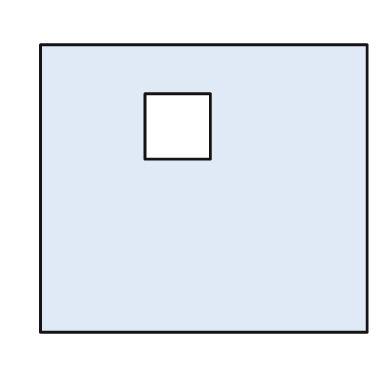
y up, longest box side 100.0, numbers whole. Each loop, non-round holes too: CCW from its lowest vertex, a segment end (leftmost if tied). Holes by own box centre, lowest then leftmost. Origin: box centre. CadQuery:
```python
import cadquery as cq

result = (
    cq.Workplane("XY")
    .moveTo(-50.0, -44.0)
    .lineTo(50.0, -44.0)
    .lineTo(50.0, 44.0)
    .lineTo(-50.0, 44.0)
    .close()
    .moveTo(-18.0, 9.0)
    .lineTo(2.0, 9.0)
    .lineTo(2.0, 29.0)
    .lineTo(-18.0, 29.0)
    .close()
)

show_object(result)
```